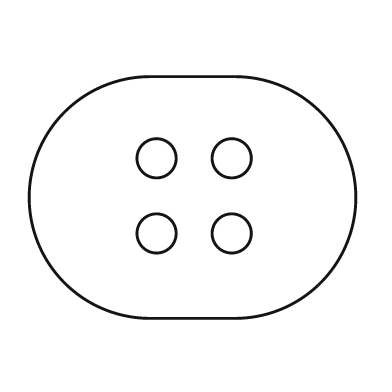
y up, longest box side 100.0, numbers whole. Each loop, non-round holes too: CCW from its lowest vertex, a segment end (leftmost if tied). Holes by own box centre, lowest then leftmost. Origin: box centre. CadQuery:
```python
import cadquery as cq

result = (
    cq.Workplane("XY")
    .moveTo(-13.0, -37.0)
    .lineTo(13.0, -37.0)
    .threePointArc((50.0, 0.0), (13.0, 37.0))
    .lineTo(-13.0, 37.0)
    .threePointArc((-50.0, 0.0), (-13.0, -37.0))
    .close()
    .moveTo(-11.0, -11.0)
    .circle(6.0)
    .moveTo(12.0, -11.0)
    .circle(6.0)
    .moveTo(-11.0, 12.0)
    .circle(6.0)
    .moveTo(12.0, 12.0)
    .circle(6.0)
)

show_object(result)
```